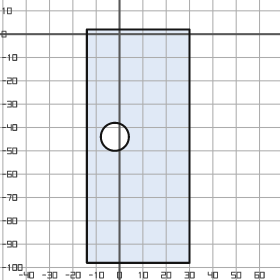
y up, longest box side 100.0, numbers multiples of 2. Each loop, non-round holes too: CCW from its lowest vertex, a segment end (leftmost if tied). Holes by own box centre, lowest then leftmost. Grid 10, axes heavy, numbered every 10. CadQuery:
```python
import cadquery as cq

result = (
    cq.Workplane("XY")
    .moveTo(-14.0, -98.0)
    .lineTo(30.0, -98.0)
    .lineTo(30.0, 2.0)
    .lineTo(-14.0, 2.0)
    .close()
    .moveTo(-2.0, -44.0)
    .circle(6.0)
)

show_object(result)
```